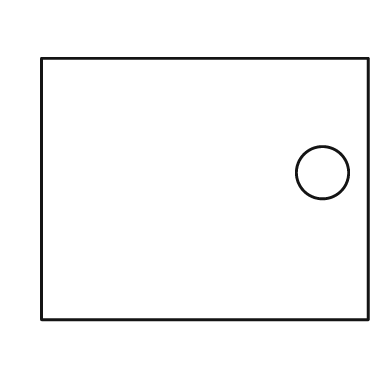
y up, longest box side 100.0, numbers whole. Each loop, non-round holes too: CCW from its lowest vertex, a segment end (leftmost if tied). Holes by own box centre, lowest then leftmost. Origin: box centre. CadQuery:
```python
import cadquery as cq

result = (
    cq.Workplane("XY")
    .moveTo(-50.0, -40.0)
    .lineTo(50.0, -40.0)
    .lineTo(50.0, 40.0)
    .lineTo(-50.0, 40.0)
    .close()
    .moveTo(36.0, 5.0)
    .circle(8.0)
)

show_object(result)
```